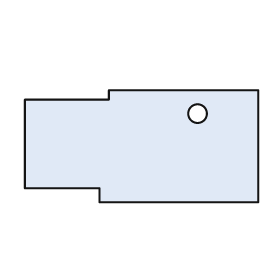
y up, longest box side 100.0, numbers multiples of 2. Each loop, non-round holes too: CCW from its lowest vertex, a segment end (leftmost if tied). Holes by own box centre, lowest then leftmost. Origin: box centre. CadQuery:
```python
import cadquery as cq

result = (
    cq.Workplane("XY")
    .moveTo(-18.0, -24.0)
    .lineTo(50.0, -24.0)
    .lineTo(50.0, 24.0)
    .lineTo(-14.0, 24.0)
    .lineTo(-14.0, 20.0)
    .lineTo(-50.0, 20.0)
    .lineTo(-50.0, -18.0)
    .lineTo(-18.0, -18.0)
    .close()
    .moveTo(24.0, 14.0)
    .circle(4.0)
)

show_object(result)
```